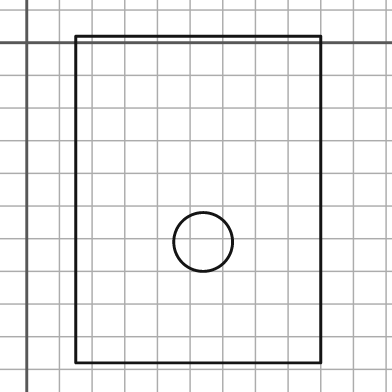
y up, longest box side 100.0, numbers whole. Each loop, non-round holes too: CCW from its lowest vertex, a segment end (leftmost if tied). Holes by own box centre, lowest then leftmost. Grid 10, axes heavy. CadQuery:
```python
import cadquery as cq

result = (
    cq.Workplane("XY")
    .moveTo(15.0, -98.0)
    .lineTo(90.0, -98.0)
    .lineTo(90.0, 2.0)
    .lineTo(15.0, 2.0)
    .close()
    .moveTo(54.0, -61.0)
    .circle(9.0)
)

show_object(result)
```